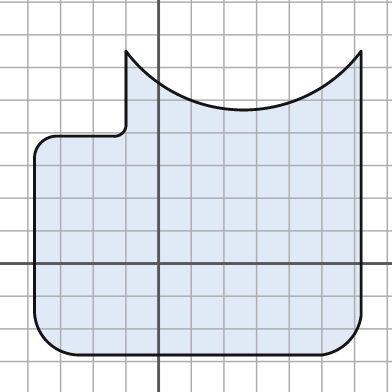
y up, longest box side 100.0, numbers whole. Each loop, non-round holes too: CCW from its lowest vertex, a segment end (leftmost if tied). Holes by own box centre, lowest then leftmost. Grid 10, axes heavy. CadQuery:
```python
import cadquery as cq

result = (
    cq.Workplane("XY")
    .moveTo(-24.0, -28.0)
    .lineTo(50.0, -28.0)
    .threePointArc((58.0, -24.0), (62.0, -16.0))
    .lineTo(62.0, 65.0)
    .threePointArc((26.0, 47.0), (-10.0, 65.0))
    .lineTo(-10.0, 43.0)
    .threePointArc((-11.0, 40.0), (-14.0, 39.0))
    .lineTo(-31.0, 39.0)
    .threePointArc((-36.0, 37.0), (-38.0, 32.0))
    .lineTo(-38.0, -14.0)
    .threePointArc((-34.0, -24.0), (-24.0, -28.0))
    .close()
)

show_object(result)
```